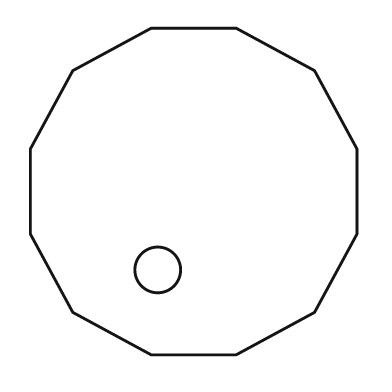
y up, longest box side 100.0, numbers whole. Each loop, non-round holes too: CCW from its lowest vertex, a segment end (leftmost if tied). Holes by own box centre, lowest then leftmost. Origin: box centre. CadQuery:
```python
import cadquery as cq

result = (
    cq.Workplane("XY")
    .moveTo(-13.0, -50.0)
    .lineTo(13.0, -50.0)
    .lineTo(37.0, -37.0)
    .lineTo(50.0, -13.0)
    .lineTo(50.0, 13.0)
    .lineTo(37.0, 37.0)
    .lineTo(13.0, 50.0)
    .lineTo(-13.0, 50.0)
    .lineTo(-37.0, 37.0)
    .lineTo(-50.0, 13.0)
    .lineTo(-50.0, -13.0)
    .lineTo(-37.0, -37.0)
    .close()
    .moveTo(-11.0, -24.0)
    .circle(7.0)
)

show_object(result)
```